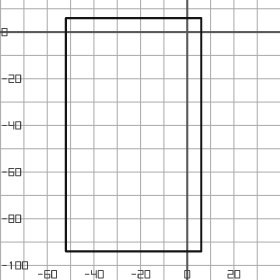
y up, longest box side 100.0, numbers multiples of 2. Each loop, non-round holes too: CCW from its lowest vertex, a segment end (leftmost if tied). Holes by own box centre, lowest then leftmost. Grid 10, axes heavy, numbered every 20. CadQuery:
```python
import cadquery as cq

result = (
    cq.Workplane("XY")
    .moveTo(-52.0, -94.0)
    .lineTo(6.0, -94.0)
    .lineTo(6.0, 6.0)
    .lineTo(-52.0, 6.0)
    .close()
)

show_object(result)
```